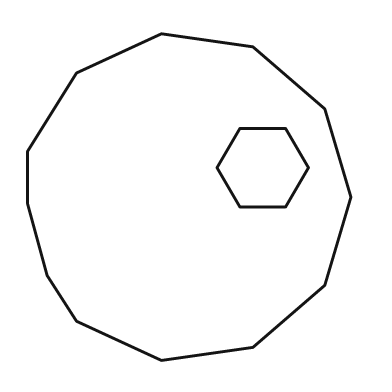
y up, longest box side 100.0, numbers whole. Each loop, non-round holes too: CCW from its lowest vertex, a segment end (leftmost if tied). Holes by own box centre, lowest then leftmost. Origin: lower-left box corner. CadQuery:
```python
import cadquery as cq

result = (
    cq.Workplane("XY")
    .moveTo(41.0, 0.0)
    .lineTo(69.0, 4.0)
    .lineTo(91.0, 23.0)
    .lineTo(99.0, 50.0)
    .lineTo(91.0, 77.0)
    .lineTo(69.0, 96.0)
    .lineTo(41.0, 100.0)
    .lineTo(15.0, 88.0)
    .lineTo(0.0, 64.0)
    .lineTo(0.0, 48.0)
    .lineTo(6.0, 26.0)
    .lineTo(15.0, 12.0)
    .close()
    .moveTo(65.0, 47.0)
    .lineTo(79.0, 47.0)
    .lineTo(86.0, 59.0)
    .lineTo(79.0, 71.0)
    .lineTo(65.0, 71.0)
    .lineTo(58.0, 59.0)
    .close()
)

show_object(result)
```